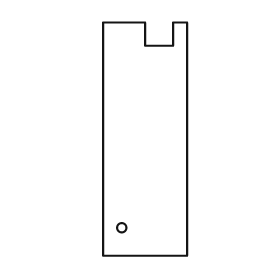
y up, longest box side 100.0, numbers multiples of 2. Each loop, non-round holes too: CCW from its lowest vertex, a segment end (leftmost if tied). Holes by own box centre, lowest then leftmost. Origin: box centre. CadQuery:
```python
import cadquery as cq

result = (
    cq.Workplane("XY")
    .moveTo(-18.0, -50.0)
    .lineTo(18.0, -50.0)
    .lineTo(18.0, 50.0)
    .lineTo(12.0, 50.0)
    .lineTo(12.0, 40.0)
    .lineTo(0.0, 40.0)
    .lineTo(0.0, 50.0)
    .lineTo(-18.0, 50.0)
    .close()
    .moveTo(-10.0, -38.0)
    .circle(2.0)
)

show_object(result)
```